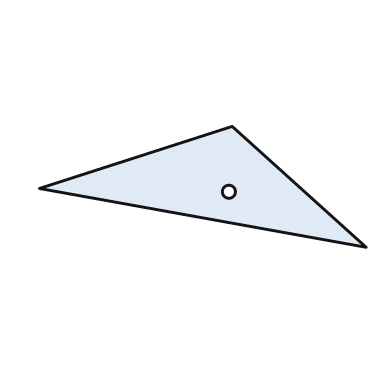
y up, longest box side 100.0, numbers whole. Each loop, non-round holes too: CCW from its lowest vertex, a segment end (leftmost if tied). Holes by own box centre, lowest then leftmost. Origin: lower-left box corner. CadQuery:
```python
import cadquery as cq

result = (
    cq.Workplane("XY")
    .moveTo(100.0, 0.0)
    .lineTo(59.0, 37.0)
    .lineTo(0.0, 18.0)
    .close()
    .moveTo(58.0, 17.0)
    .circle(2.0)
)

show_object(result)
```